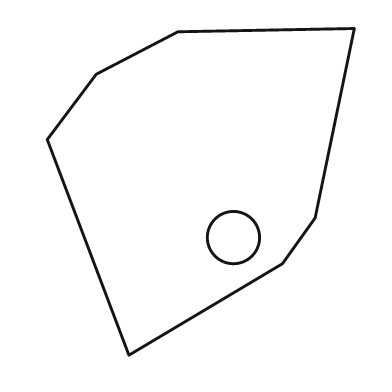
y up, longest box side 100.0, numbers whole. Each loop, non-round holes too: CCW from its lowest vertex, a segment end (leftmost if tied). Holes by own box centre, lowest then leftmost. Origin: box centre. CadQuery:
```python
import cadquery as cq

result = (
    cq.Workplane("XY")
    .moveTo(-22.0, -50.0)
    .lineTo(25.0, -22.0)
    .lineTo(35.0, -8.0)
    .lineTo(47.0, 50.0)
    .lineTo(-7.0, 49.0)
    .lineTo(-32.0, 36.0)
    .lineTo(-47.0, 16.0)
    .close()
    .moveTo(10.0, -14.0)
    .circle(8.0)
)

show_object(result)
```